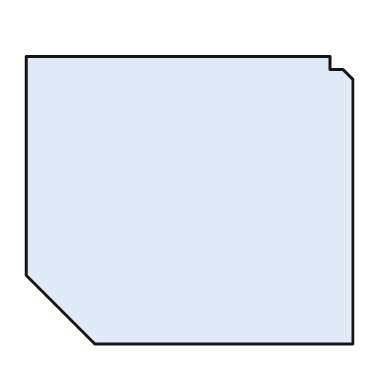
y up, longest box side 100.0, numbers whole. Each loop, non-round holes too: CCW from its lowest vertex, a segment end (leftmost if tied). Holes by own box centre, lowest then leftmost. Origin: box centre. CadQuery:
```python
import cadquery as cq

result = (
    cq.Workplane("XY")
    .moveTo(-29.0, -44.0)
    .lineTo(50.0, -44.0)
    .lineTo(50.0, 37.0)
    .lineTo(47.0, 40.0)
    .lineTo(43.0, 40.0)
    .lineTo(43.0, 44.0)
    .lineTo(-50.0, 44.0)
    .lineTo(-50.0, -23.0)
    .close()
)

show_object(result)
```